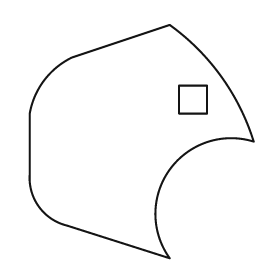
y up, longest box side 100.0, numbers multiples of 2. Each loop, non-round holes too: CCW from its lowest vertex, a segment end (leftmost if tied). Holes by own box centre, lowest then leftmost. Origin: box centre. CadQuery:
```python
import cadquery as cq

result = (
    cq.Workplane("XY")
    .moveTo(12.0, -50.0)
    .threePointArc((12.0, -12.0), (48.0, 0.0))
    .threePointArc((34.0, 28.0), (12.0, 50.0))
    .lineTo(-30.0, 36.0)
    .threePointArc((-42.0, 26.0), (-48.0, 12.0))
    .lineTo(-48.0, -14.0)
    .threePointArc((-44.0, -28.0), (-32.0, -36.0))
    .close()
    .moveTo(16.0, 12.0)
    .lineTo(28.0, 12.0)
    .lineTo(28.0, 24.0)
    .lineTo(16.0, 24.0)
    .close()
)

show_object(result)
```